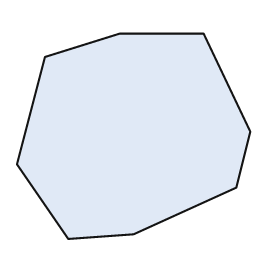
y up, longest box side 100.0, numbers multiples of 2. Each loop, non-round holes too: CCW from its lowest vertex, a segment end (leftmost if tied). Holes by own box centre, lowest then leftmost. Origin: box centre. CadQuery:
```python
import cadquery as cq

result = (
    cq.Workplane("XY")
    .moveTo(-28.0, -44.0)
    .lineTo(0.0, -42.0)
    .lineTo(44.0, -22.0)
    .lineTo(50.0, 2.0)
    .lineTo(30.0, 44.0)
    .lineTo(-6.0, 44.0)
    .lineTo(-38.0, 34.0)
    .lineTo(-50.0, -12.0)
    .close()
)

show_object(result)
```